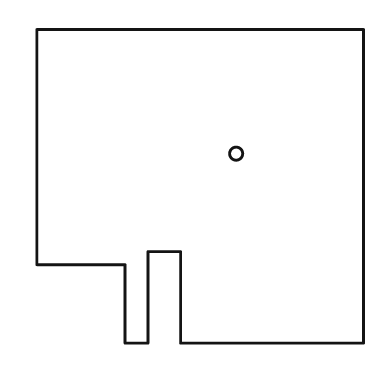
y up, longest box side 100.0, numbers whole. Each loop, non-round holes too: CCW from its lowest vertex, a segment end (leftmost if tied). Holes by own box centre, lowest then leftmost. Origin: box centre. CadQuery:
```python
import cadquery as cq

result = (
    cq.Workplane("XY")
    .moveTo(-23.0, -48.0)
    .lineTo(-16.0, -48.0)
    .lineTo(-16.0, -20.0)
    .lineTo(-6.0, -20.0)
    .lineTo(-6.0, -48.0)
    .lineTo(50.0, -48.0)
    .lineTo(50.0, 48.0)
    .lineTo(-50.0, 48.0)
    .lineTo(-50.0, -24.0)
    .lineTo(-23.0, -24.0)
    .close()
    .moveTo(11.0, 10.0)
    .circle(2.0)
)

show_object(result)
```